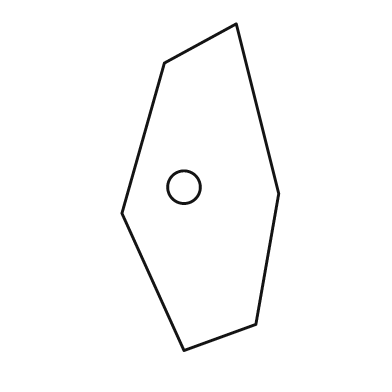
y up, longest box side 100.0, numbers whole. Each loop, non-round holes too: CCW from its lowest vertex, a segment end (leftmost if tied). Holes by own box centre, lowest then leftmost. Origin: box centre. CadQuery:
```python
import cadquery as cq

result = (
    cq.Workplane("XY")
    .moveTo(-5.0, -50.0)
    .lineTo(17.0, -42.0)
    .lineTo(24.0, -2.0)
    .lineTo(11.0, 50.0)
    .lineTo(-11.0, 38.0)
    .lineTo(-24.0, -8.0)
    .close()
    .moveTo(-5.0, 0.0)
    .circle(5.0)
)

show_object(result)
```